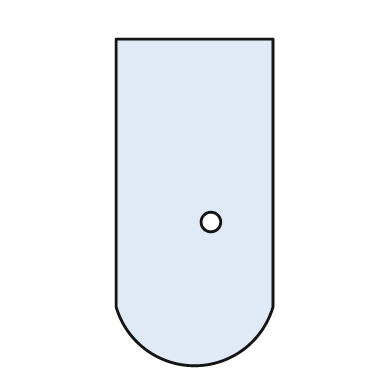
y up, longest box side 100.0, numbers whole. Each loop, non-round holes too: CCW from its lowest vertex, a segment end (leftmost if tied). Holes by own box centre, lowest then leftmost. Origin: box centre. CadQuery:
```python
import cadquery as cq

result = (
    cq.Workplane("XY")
    .moveTo(-24.0, -32.0)
    .threePointArc((0.0, -50.0), (24.0, -32.0))
    .lineTo(24.0, 50.0)
    .lineTo(-24.0, 50.0)
    .close()
    .moveTo(5.0, -6.0)
    .circle(3.0)
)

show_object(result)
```